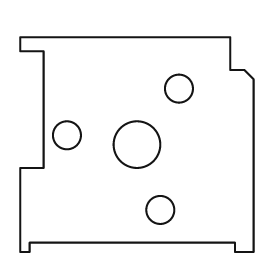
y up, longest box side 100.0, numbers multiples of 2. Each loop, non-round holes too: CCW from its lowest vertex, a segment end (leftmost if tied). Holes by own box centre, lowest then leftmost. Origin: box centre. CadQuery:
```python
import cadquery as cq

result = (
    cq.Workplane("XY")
    .moveTo(-50.0, -46.0)
    .lineTo(-46.0, -46.0)
    .lineTo(-46.0, -42.0)
    .lineTo(42.0, -42.0)
    .lineTo(42.0, -46.0)
    .lineTo(50.0, -46.0)
    .lineTo(50.0, 28.0)
    .lineTo(46.0, 32.0)
    .lineTo(40.0, 32.0)
    .lineTo(40.0, 46.0)
    .lineTo(-50.0, 46.0)
    .lineTo(-50.0, 40.0)
    .lineTo(-40.0, 40.0)
    .lineTo(-40.0, -10.0)
    .lineTo(-50.0, -10.0)
    .close()
    .moveTo(10.0, -28.0)
    .circle(6.0)
    .moveTo(0.0, 0.0)
    .circle(10.0)
    .moveTo(-30.0, 4.0)
    .circle(6.0)
    .moveTo(18.0, 24.0)
    .circle(6.0)
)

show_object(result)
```